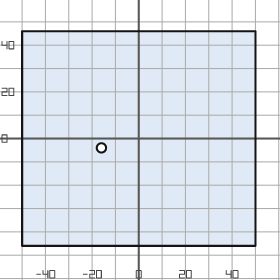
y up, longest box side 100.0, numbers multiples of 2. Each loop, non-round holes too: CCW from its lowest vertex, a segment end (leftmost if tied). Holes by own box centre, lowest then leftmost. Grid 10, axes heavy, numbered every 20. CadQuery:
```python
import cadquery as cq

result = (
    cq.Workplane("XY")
    .moveTo(-50.0, -46.0)
    .lineTo(50.0, -46.0)
    .lineTo(50.0, 46.0)
    .lineTo(-50.0, 46.0)
    .close()
    .moveTo(-16.0, -4.0)
    .circle(2.0)
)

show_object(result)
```